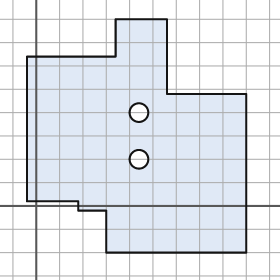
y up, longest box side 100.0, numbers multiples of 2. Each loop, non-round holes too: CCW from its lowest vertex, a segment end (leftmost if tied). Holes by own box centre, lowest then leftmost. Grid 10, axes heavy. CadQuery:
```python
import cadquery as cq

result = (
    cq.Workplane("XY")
    .moveTo(30.0, -20.0)
    .lineTo(90.0, -20.0)
    .lineTo(90.0, 48.0)
    .lineTo(56.0, 48.0)
    .lineTo(56.0, 80.0)
    .lineTo(34.0, 80.0)
    .lineTo(34.0, 64.0)
    .lineTo(-4.0, 64.0)
    .lineTo(-4.0, 2.0)
    .lineTo(18.0, 2.0)
    .lineTo(18.0, -2.0)
    .lineTo(30.0, -2.0)
    .close()
    .moveTo(44.0, 20.0)
    .circle(4.0)
    .moveTo(44.0, 40.0)
    .circle(4.0)
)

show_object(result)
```